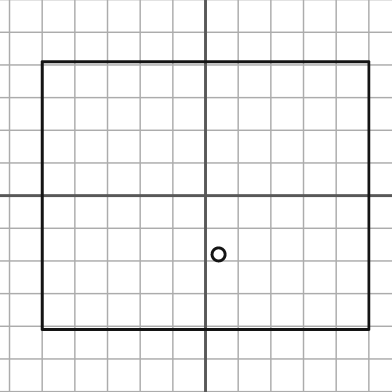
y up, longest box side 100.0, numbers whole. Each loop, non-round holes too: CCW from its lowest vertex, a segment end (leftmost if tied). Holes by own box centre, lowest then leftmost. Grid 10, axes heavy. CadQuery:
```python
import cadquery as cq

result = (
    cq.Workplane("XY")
    .moveTo(-50.0, -41.0)
    .lineTo(50.0, -41.0)
    .lineTo(50.0, 41.0)
    .lineTo(-50.0, 41.0)
    .close()
    .moveTo(4.0, -18.0)
    .circle(2.0)
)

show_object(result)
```